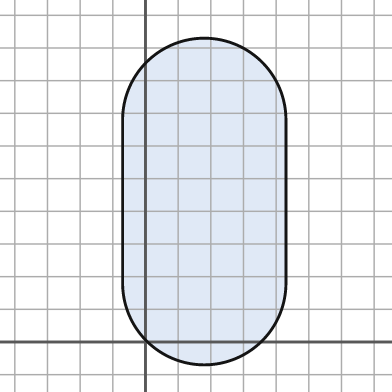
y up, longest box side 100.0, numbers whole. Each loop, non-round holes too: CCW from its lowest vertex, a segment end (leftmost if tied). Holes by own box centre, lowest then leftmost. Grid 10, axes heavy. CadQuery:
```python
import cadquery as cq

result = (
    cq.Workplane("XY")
    .moveTo(-7.0, 18.0)
    .threePointArc((18.0, -7.0), (43.0, 18.0))
    .lineTo(43.0, 68.0)
    .threePointArc((18.0, 93.0), (-7.0, 68.0))
    .close()
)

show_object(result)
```